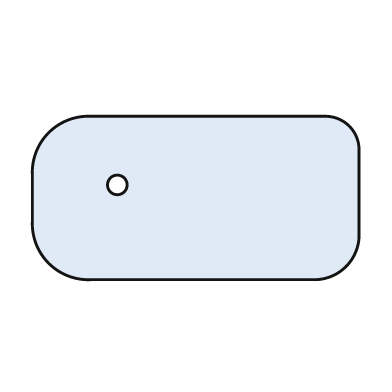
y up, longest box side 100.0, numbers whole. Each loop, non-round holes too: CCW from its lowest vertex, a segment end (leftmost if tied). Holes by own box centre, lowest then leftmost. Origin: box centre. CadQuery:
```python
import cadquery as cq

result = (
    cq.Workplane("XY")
    .moveTo(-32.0, -25.0)
    .lineTo(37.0, -25.0)
    .threePointArc((46.0, -21.0), (50.0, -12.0))
    .lineTo(50.0, 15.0)
    .threePointArc((47.0, 22.0), (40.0, 25.0))
    .lineTo(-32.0, 25.0)
    .threePointArc((-45.0, 20.0), (-50.0, 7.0))
    .lineTo(-50.0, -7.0)
    .threePointArc((-45.0, -20.0), (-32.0, -25.0))
    .close()
    .moveTo(-24.0, 4.0)
    .circle(3.0)
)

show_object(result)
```